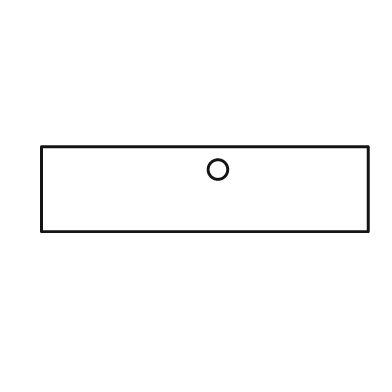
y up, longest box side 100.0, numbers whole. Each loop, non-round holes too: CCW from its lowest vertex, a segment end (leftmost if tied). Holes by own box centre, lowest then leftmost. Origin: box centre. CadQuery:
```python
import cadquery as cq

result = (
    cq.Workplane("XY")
    .moveTo(-50.0, -13.0)
    .lineTo(50.0, -13.0)
    .lineTo(50.0, 13.0)
    .lineTo(-50.0, 13.0)
    .close()
    .moveTo(4.0, 6.0)
    .circle(3.0)
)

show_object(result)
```